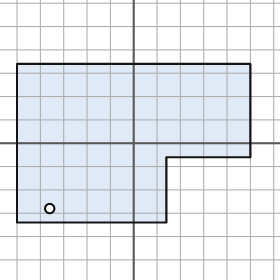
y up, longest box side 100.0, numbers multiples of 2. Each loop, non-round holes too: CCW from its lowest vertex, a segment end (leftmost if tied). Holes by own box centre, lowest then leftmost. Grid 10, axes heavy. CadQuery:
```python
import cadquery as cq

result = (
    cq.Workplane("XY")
    .moveTo(-50.0, -34.0)
    .lineTo(14.0, -34.0)
    .lineTo(14.0, -6.0)
    .lineTo(50.0, -6.0)
    .lineTo(50.0, 34.0)
    .lineTo(-50.0, 34.0)
    .close()
    .moveTo(-36.0, -28.0)
    .circle(2.0)
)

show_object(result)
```